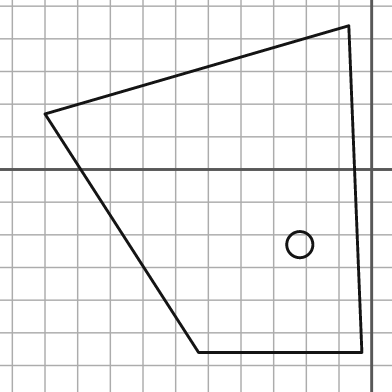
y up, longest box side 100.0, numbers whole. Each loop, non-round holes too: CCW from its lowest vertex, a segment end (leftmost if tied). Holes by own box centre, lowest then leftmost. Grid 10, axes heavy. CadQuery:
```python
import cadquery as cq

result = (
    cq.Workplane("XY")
    .moveTo(-53.0, -56.0)
    .lineTo(-3.0, -56.0)
    .lineTo(-7.0, 44.0)
    .lineTo(-100.0, 17.0)
    .close()
    .moveTo(-22.0, -23.0)
    .circle(4.0)
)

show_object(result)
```